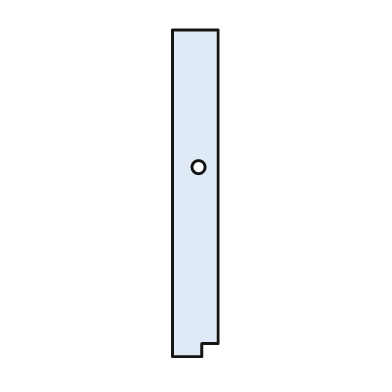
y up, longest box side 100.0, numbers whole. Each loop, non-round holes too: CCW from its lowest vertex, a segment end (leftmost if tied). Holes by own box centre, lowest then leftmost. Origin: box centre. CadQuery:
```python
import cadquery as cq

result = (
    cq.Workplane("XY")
    .moveTo(-7.0, -50.0)
    .lineTo(2.0, -50.0)
    .lineTo(2.0, -46.0)
    .lineTo(7.0, -46.0)
    .lineTo(7.0, 50.0)
    .lineTo(-7.0, 50.0)
    .close()
    .moveTo(1.0, 8.0)
    .circle(2.0)
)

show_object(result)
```